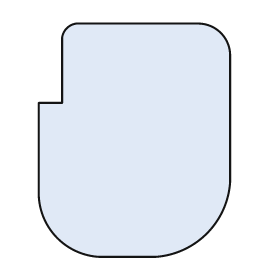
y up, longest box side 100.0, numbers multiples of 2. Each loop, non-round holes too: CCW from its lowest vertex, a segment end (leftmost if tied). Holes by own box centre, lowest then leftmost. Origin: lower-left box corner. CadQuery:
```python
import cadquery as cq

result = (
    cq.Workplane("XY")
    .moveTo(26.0, 0.0)
    .lineTo(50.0, 0.0)
    .threePointArc((72.0, 10.0), (82.0, 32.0))
    .lineTo(82.0, 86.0)
    .threePointArc((78.0, 96.0), (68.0, 100.0))
    .lineTo(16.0, 100.0)
    .threePointArc((12.0, 98.0), (10.0, 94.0))
    .lineTo(10.0, 66.0)
    .lineTo(0.0, 66.0)
    .lineTo(0.0, 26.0)
    .threePointArc((8.0, 8.0), (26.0, 0.0))
    .close()
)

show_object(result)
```